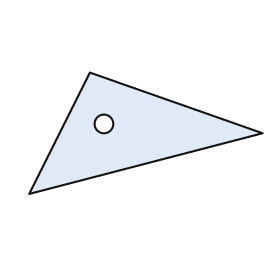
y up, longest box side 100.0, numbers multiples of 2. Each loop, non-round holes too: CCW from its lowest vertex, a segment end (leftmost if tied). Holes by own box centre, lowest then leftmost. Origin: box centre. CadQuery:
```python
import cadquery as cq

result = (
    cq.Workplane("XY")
    .moveTo(-50.0, -26.0)
    .lineTo(50.0, 0.0)
    .lineTo(-24.0, 26.0)
    .close()
    .moveTo(-18.0, 4.0)
    .circle(4.0)
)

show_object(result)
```